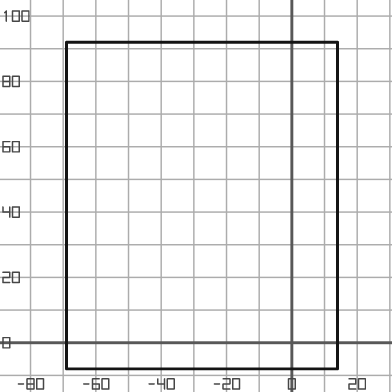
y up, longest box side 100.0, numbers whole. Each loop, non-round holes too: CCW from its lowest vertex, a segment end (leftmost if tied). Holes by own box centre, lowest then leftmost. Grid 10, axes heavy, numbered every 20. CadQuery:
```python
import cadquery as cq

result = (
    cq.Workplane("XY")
    .moveTo(-69.0, -8.0)
    .lineTo(14.0, -8.0)
    .lineTo(14.0, 92.0)
    .lineTo(-69.0, 92.0)
    .close()
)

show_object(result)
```